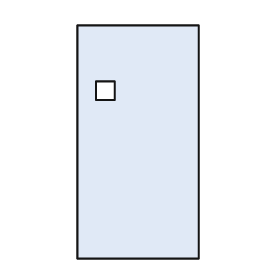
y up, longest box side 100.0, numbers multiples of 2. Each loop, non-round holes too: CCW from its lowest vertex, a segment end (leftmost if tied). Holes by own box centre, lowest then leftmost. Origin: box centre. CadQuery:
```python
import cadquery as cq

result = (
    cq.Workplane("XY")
    .moveTo(-26.0, -50.0)
    .lineTo(26.0, -50.0)
    .lineTo(26.0, 50.0)
    .lineTo(-26.0, 50.0)
    .close()
    .moveTo(-18.0, 18.0)
    .lineTo(-10.0, 18.0)
    .lineTo(-10.0, 26.0)
    .lineTo(-18.0, 26.0)
    .close()
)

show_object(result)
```